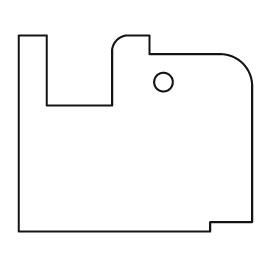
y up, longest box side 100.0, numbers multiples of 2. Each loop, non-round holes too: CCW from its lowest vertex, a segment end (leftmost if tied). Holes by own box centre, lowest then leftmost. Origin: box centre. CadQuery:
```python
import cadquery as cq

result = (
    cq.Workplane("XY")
    .moveTo(-50.0, -42.0)
    .lineTo(32.0, -42.0)
    .lineTo(32.0, -38.0)
    .lineTo(50.0, -38.0)
    .lineTo(50.0, 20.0)
    .threePointArc((46.0, 30.0), (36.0, 34.0))
    .lineTo(6.0, 34.0)
    .lineTo(6.0, 42.0)
    .lineTo(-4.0, 42.0)
    .threePointArc((-8.0, 40.0), (-10.0, 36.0))
    .lineTo(-10.0, 12.0)
    .lineTo(-38.0, 12.0)
    .lineTo(-38.0, 42.0)
    .lineTo(-50.0, 42.0)
    .close()
    .moveTo(12.0, 22.0)
    .circle(4.0)
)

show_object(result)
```